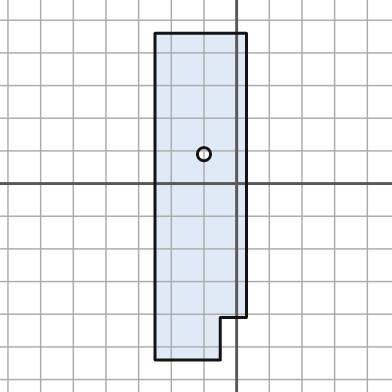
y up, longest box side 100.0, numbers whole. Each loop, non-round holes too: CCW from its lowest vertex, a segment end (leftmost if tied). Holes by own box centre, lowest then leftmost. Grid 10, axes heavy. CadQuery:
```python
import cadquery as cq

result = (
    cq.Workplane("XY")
    .moveTo(-25.0, -54.0)
    .lineTo(-5.0, -54.0)
    .lineTo(-5.0, -41.0)
    .lineTo(3.0, -41.0)
    .lineTo(3.0, 46.0)
    .lineTo(-25.0, 46.0)
    .close()
    .moveTo(-10.0, 9.0)
    .circle(2.0)
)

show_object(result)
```